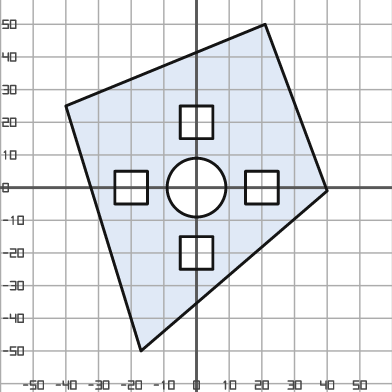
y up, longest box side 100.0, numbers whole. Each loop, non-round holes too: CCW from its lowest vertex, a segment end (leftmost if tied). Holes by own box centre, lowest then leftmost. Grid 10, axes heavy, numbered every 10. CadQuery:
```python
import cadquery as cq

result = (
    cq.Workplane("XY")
    .moveTo(-17.0, -50.0)
    .lineTo(40.0, -1.0)
    .lineTo(21.0, 50.0)
    .lineTo(-40.0, 25.0)
    .close()
    .moveTo(-5.0, -25.0)
    .lineTo(5.0, -25.0)
    .lineTo(5.0, -15.0)
    .lineTo(-5.0, -15.0)
    .close()
    .moveTo(-25.0, -5.0)
    .lineTo(-15.0, -5.0)
    .lineTo(-15.0, 5.0)
    .lineTo(-25.0, 5.0)
    .close()
    .moveTo(0.0, 0.0)
    .circle(9.0)
    .moveTo(15.0, -5.0)
    .lineTo(25.0, -5.0)
    .lineTo(25.0, 5.0)
    .lineTo(15.0, 5.0)
    .close()
    .moveTo(-5.0, 15.0)
    .lineTo(5.0, 15.0)
    .lineTo(5.0, 25.0)
    .lineTo(-5.0, 25.0)
    .close()
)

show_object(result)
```